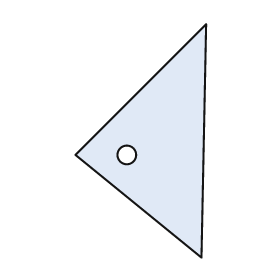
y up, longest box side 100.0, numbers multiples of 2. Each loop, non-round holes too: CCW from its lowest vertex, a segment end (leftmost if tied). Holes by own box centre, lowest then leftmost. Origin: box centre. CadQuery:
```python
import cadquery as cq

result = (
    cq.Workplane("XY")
    .moveTo(26.0, -50.0)
    .lineTo(28.0, 50.0)
    .lineTo(-28.0, -6.0)
    .close()
    .moveTo(-6.0, -6.0)
    .circle(4.0)
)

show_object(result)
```